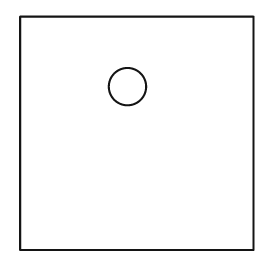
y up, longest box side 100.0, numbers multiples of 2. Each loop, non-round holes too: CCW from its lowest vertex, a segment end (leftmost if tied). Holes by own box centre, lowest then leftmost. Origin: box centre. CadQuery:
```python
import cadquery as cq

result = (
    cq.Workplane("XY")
    .moveTo(-50.0, -50.0)
    .lineTo(50.0, -50.0)
    .lineTo(50.0, 50.0)
    .lineTo(-50.0, 50.0)
    .close()
    .moveTo(-4.0, 20.0)
    .circle(8.0)
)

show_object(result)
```